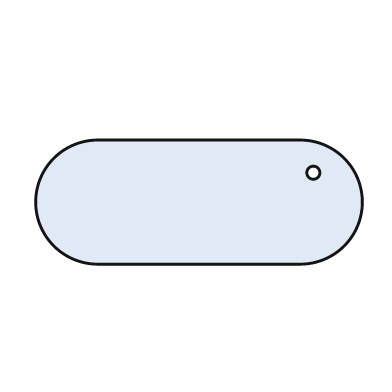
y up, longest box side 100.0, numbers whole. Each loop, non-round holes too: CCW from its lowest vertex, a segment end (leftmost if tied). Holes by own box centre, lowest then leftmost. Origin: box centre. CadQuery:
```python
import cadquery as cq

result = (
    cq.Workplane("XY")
    .moveTo(-31.0, -19.0)
    .lineTo(31.0, -19.0)
    .threePointArc((50.0, 0.0), (31.0, 19.0))
    .lineTo(-31.0, 19.0)
    .threePointArc((-50.0, 0.0), (-31.0, -19.0))
    .close()
    .moveTo(35.0, 9.0)
    .circle(2.0)
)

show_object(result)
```